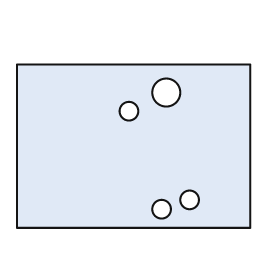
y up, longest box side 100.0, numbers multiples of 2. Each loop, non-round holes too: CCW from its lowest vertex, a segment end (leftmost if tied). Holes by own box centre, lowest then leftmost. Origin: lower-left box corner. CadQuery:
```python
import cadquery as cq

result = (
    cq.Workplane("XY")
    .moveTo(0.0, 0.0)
    .lineTo(100.0, 0.0)
    .lineTo(100.0, 70.0)
    .lineTo(0.0, 70.0)
    .close()
    .moveTo(62.0, 8.0)
    .circle(4.0)
    .moveTo(74.0, 12.0)
    .circle(4.0)
    .moveTo(48.0, 50.0)
    .circle(4.0)
    .moveTo(64.0, 58.0)
    .circle(6.0)
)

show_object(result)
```